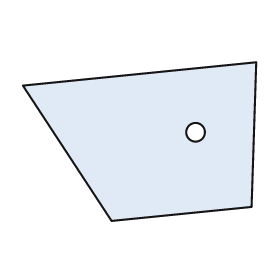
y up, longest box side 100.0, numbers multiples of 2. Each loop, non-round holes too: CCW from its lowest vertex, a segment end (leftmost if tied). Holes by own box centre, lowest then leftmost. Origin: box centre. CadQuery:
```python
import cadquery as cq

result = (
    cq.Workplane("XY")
    .moveTo(-12.0, -34.0)
    .lineTo(48.0, -28.0)
    .lineTo(50.0, 34.0)
    .lineTo(-50.0, 24.0)
    .close()
    .moveTo(24.0, 4.0)
    .circle(4.0)
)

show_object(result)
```